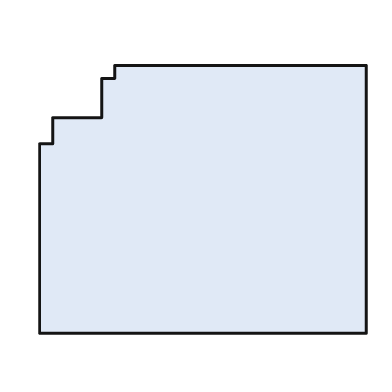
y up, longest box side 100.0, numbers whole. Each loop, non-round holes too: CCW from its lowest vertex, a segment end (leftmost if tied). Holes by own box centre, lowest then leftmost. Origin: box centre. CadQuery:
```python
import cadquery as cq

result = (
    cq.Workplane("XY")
    .moveTo(-50.0, -41.0)
    .lineTo(50.0, -41.0)
    .lineTo(50.0, 41.0)
    .lineTo(-27.0, 41.0)
    .lineTo(-27.0, 37.0)
    .lineTo(-31.0, 37.0)
    .lineTo(-31.0, 25.0)
    .lineTo(-46.0, 25.0)
    .lineTo(-46.0, 17.0)
    .lineTo(-50.0, 17.0)
    .close()
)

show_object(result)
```